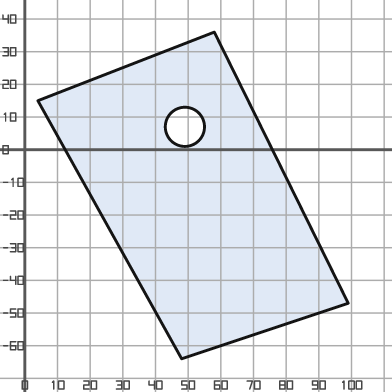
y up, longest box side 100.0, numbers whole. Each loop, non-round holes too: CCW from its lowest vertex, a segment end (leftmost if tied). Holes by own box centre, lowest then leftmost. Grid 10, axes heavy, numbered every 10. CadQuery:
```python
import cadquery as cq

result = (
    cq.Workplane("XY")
    .moveTo(48.0, -64.0)
    .lineTo(99.0, -47.0)
    .lineTo(58.0, 36.0)
    .lineTo(4.0, 15.0)
    .close()
    .moveTo(49.0, 7.0)
    .circle(6.0)
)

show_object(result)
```